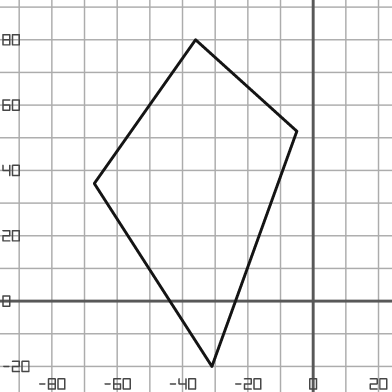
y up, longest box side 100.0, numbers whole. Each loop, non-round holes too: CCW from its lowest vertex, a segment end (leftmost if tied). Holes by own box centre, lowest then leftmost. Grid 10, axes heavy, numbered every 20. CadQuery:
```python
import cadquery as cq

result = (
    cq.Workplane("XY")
    .moveTo(-31.0, -20.0)
    .lineTo(-5.0, 52.0)
    .lineTo(-36.0, 80.0)
    .lineTo(-67.0, 36.0)
    .close()
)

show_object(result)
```